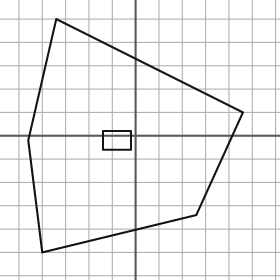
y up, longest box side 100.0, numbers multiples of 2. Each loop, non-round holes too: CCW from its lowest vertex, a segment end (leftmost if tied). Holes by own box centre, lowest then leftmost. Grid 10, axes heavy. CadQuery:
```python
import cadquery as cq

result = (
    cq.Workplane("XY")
    .moveTo(-40.0, -50.0)
    .lineTo(26.0, -34.0)
    .lineTo(46.0, 10.0)
    .lineTo(-34.0, 50.0)
    .lineTo(-46.0, -2.0)
    .close()
    .moveTo(-14.0, -6.0)
    .lineTo(-2.0, -6.0)
    .lineTo(-2.0, 2.0)
    .lineTo(-14.0, 2.0)
    .close()
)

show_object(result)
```